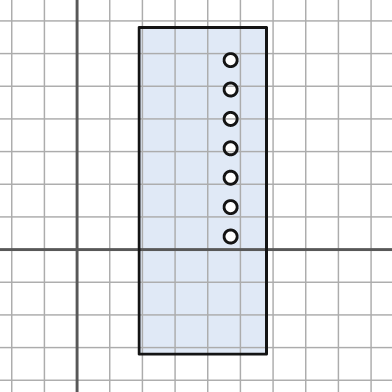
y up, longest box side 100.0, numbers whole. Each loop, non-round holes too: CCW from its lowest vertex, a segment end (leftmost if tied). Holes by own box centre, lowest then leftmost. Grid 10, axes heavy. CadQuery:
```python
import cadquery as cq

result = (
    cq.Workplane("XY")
    .moveTo(19.0, -32.0)
    .lineTo(58.0, -32.0)
    .lineTo(58.0, 68.0)
    .lineTo(19.0, 68.0)
    .close()
    .moveTo(47.0, 4.0)
    .circle(2.0)
    .moveTo(47.0, 13.0)
    .circle(2.0)
    .moveTo(47.0, 22.0)
    .circle(2.0)
    .moveTo(47.0, 31.0)
    .circle(2.0)
    .moveTo(47.0, 40.0)
    .circle(2.0)
    .moveTo(47.0, 49.0)
    .circle(2.0)
    .moveTo(47.0, 58.0)
    .circle(2.0)
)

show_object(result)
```